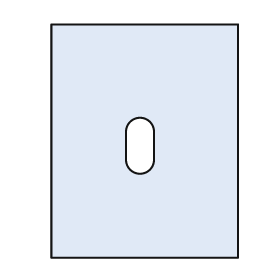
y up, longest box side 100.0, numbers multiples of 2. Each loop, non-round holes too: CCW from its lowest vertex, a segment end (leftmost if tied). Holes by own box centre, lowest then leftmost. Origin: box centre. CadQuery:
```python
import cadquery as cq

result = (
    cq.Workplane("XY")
    .moveTo(-40.0, -50.0)
    .lineTo(40.0, -50.0)
    .lineTo(40.0, 50.0)
    .lineTo(-40.0, 50.0)
    .close()
    .moveTo(-8.0, -8.0)
    .threePointArc((-2.0, -14.0), (4.0, -8.0))
    .lineTo(4.0, 4.0)
    .threePointArc((-2.0, 10.0), (-8.0, 4.0))
    .close()
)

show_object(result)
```